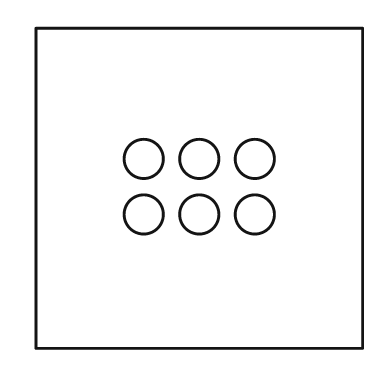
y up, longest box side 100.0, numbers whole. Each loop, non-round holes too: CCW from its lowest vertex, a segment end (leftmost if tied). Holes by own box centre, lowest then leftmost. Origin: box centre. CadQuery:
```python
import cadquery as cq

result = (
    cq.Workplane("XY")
    .moveTo(-50.0, -49.0)
    .lineTo(50.0, -49.0)
    .lineTo(50.0, 49.0)
    .lineTo(-50.0, 49.0)
    .close()
    .moveTo(-17.0, -8.0)
    .circle(6.0)
    .moveTo(0.0, -8.0)
    .circle(6.0)
    .moveTo(17.0, -8.0)
    .circle(6.0)
    .moveTo(-17.0, 9.0)
    .circle(6.0)
    .moveTo(0.0, 9.0)
    .circle(6.0)
    .moveTo(17.0, 9.0)
    .circle(6.0)
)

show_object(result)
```